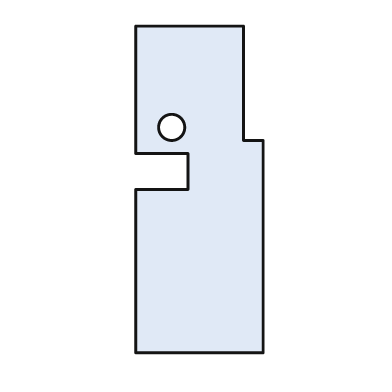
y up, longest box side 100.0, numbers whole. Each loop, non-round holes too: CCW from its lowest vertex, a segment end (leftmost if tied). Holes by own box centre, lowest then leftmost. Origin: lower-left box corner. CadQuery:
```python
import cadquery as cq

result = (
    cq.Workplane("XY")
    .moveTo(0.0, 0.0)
    .lineTo(39.0, 0.0)
    .lineTo(39.0, 65.0)
    .lineTo(33.0, 65.0)
    .lineTo(33.0, 100.0)
    .lineTo(0.0, 100.0)
    .lineTo(0.0, 61.0)
    .lineTo(16.0, 61.0)
    .lineTo(16.0, 50.0)
    .lineTo(0.0, 50.0)
    .close()
    .moveTo(11.0, 69.0)
    .circle(4.0)
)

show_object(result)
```